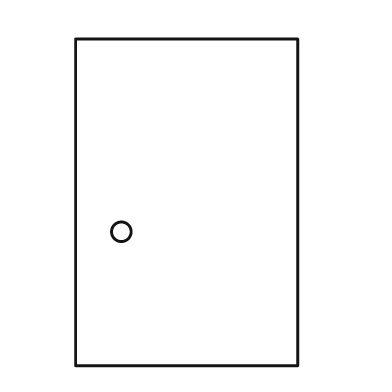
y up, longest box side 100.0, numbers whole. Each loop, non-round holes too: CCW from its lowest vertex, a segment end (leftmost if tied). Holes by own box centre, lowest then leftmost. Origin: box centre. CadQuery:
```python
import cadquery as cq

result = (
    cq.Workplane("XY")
    .moveTo(-34.0, -50.0)
    .lineTo(34.0, -50.0)
    .lineTo(34.0, 50.0)
    .lineTo(-34.0, 50.0)
    .close()
    .moveTo(-20.0, -9.0)
    .circle(3.0)
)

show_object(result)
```